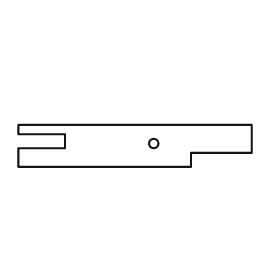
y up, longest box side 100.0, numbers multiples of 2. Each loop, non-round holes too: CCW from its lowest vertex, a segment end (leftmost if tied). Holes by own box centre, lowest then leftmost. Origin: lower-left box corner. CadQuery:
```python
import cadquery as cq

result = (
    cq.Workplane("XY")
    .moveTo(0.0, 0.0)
    .lineTo(74.0, 0.0)
    .lineTo(74.0, 6.0)
    .lineTo(100.0, 6.0)
    .lineTo(100.0, 18.0)
    .lineTo(0.0, 18.0)
    .lineTo(0.0, 14.0)
    .lineTo(20.0, 14.0)
    .lineTo(20.0, 8.0)
    .lineTo(0.0, 8.0)
    .close()
    .moveTo(58.0, 10.0)
    .circle(2.0)
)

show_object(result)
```